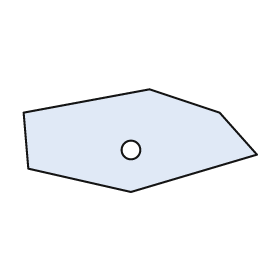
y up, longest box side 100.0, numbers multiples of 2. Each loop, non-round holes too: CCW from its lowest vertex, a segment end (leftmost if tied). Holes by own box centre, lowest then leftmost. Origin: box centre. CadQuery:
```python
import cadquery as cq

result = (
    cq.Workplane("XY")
    .moveTo(-4.0, -22.0)
    .lineTo(50.0, -6.0)
    .lineTo(34.0, 12.0)
    .lineTo(4.0, 22.0)
    .lineTo(-50.0, 12.0)
    .lineTo(-48.0, -12.0)
    .close()
    .moveTo(-4.0, -4.0)
    .circle(4.0)
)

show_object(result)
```